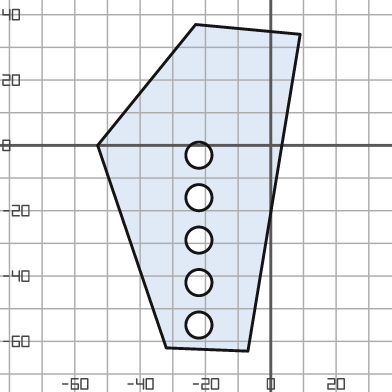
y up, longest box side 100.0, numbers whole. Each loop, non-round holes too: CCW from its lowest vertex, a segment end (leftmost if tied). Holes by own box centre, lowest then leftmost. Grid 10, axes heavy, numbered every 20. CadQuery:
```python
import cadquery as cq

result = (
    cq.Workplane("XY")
    .moveTo(-7.0, -63.0)
    .lineTo(9.0, 34.0)
    .lineTo(-23.0, 37.0)
    .lineTo(-53.0, 0.0)
    .lineTo(-32.0, -62.0)
    .close()
    .moveTo(-22.0, -55.0)
    .circle(4.0)
    .moveTo(-22.0, -42.0)
    .circle(4.0)
    .moveTo(-22.0, -29.0)
    .circle(4.0)
    .moveTo(-22.0, -16.0)
    .circle(4.0)
    .moveTo(-22.0, -3.0)
    .circle(4.0)
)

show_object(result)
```